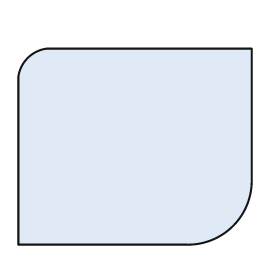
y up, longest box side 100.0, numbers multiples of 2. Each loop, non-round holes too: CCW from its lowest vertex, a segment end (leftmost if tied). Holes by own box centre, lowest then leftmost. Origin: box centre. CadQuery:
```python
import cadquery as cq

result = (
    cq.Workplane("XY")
    .moveTo(-50.0, -42.0)
    .lineTo(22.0, -42.0)
    .threePointArc((42.0, -34.0), (50.0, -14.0))
    .lineTo(50.0, 42.0)
    .lineTo(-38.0, 42.0)
    .threePointArc((-46.0, 38.0), (-50.0, 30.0))
    .close()
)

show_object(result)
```